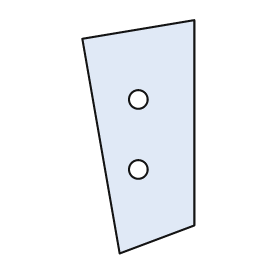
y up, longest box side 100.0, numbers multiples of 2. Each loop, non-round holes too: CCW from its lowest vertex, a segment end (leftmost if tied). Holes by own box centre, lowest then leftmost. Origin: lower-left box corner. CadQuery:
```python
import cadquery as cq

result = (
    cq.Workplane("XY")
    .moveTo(16.0, 0.0)
    .lineTo(48.0, 12.0)
    .lineTo(48.0, 100.0)
    .lineTo(0.0, 92.0)
    .close()
    .moveTo(24.0, 36.0)
    .circle(4.0)
    .moveTo(24.0, 66.0)
    .circle(4.0)
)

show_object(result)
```